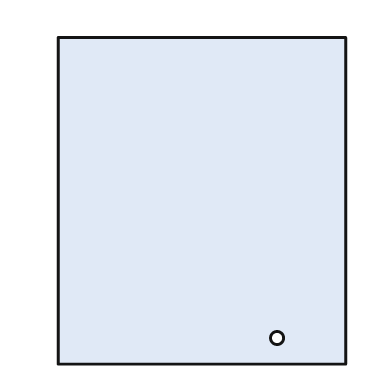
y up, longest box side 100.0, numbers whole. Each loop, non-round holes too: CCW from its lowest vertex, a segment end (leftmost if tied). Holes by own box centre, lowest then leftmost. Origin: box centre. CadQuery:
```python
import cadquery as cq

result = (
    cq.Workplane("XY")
    .moveTo(-44.0, -50.0)
    .lineTo(44.0, -50.0)
    .lineTo(44.0, 50.0)
    .lineTo(-44.0, 50.0)
    .close()
    .moveTo(23.0, -42.0)
    .circle(2.0)
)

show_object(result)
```